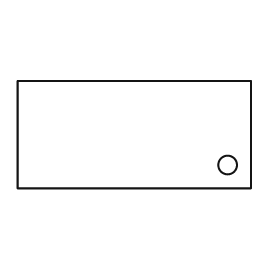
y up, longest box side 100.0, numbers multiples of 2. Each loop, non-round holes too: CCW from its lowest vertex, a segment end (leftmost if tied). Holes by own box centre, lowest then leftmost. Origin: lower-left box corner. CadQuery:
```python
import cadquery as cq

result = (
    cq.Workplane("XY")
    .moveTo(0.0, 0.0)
    .lineTo(100.0, 0.0)
    .lineTo(100.0, 46.0)
    .lineTo(0.0, 46.0)
    .close()
    .moveTo(90.0, 10.0)
    .circle(4.0)
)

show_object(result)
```